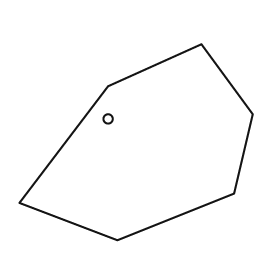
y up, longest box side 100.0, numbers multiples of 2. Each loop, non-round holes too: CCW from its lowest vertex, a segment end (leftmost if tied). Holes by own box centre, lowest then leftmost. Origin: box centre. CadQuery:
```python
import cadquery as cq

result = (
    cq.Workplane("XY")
    .moveTo(-8.0, -42.0)
    .lineTo(42.0, -22.0)
    .lineTo(50.0, 12.0)
    .lineTo(28.0, 42.0)
    .lineTo(-12.0, 24.0)
    .lineTo(-50.0, -26.0)
    .close()
    .moveTo(-12.0, 10.0)
    .circle(2.0)
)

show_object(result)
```